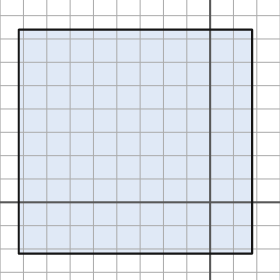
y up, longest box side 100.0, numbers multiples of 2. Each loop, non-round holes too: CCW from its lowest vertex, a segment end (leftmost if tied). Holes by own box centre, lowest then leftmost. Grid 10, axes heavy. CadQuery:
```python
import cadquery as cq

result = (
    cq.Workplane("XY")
    .moveTo(-82.0, -22.0)
    .lineTo(18.0, -22.0)
    .lineTo(18.0, 74.0)
    .lineTo(-82.0, 74.0)
    .close()
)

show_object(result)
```